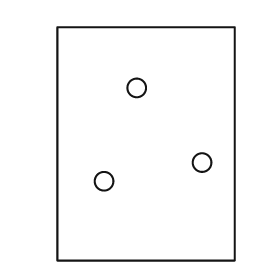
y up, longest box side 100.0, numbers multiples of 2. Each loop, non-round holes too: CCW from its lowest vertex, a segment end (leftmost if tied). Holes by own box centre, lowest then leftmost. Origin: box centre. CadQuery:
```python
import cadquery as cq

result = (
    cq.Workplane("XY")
    .moveTo(-38.0, -50.0)
    .lineTo(38.0, -50.0)
    .lineTo(38.0, 50.0)
    .lineTo(-38.0, 50.0)
    .close()
    .moveTo(-18.0, -16.0)
    .circle(4.0)
    .moveTo(24.0, -8.0)
    .circle(4.0)
    .moveTo(-4.0, 24.0)
    .circle(4.0)
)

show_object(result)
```